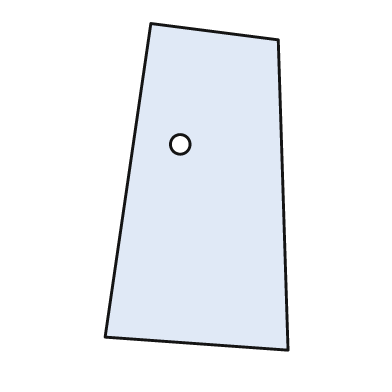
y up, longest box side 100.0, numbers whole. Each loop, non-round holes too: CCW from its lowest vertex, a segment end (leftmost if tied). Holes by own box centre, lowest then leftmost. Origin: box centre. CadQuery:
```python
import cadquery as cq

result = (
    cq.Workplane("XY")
    .moveTo(28.0, -50.0)
    .lineTo(25.0, 45.0)
    .lineTo(-14.0, 50.0)
    .lineTo(-28.0, -46.0)
    .close()
    .moveTo(-5.0, 13.0)
    .circle(3.0)
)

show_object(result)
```